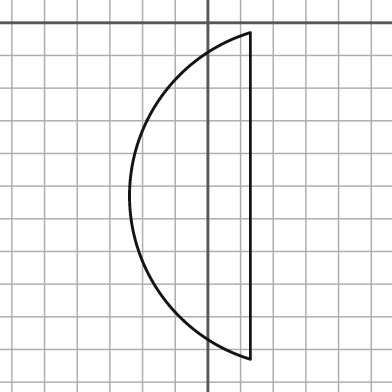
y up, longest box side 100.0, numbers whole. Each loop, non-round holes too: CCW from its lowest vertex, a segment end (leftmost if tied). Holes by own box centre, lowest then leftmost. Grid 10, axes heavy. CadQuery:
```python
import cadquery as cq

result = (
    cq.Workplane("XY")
    .moveTo(13.0, -103.0)
    .lineTo(13.0, -3.0)
    .threePointArc((-24.0, -53.0), (13.0, -103.0))
    .close()
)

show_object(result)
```